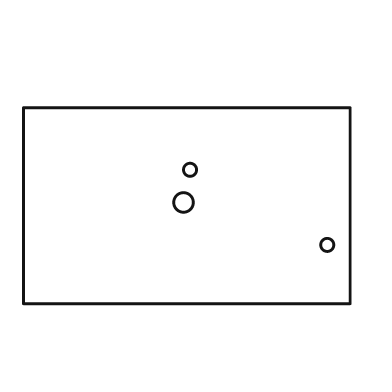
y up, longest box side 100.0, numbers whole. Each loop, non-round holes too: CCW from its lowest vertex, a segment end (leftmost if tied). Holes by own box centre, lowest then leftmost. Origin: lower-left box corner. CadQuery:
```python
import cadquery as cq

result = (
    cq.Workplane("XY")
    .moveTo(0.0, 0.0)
    .lineTo(100.0, 0.0)
    .lineTo(100.0, 60.0)
    .lineTo(0.0, 60.0)
    .close()
    .moveTo(93.0, 18.0)
    .circle(2.0)
    .moveTo(49.0, 31.0)
    .circle(3.0)
    .moveTo(51.0, 41.0)
    .circle(2.0)
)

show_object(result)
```